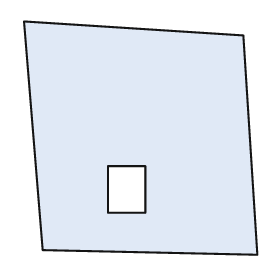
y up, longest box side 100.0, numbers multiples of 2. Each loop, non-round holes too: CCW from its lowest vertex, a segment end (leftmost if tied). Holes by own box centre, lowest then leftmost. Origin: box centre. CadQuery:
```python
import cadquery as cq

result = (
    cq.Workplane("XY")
    .moveTo(50.0, -50.0)
    .lineTo(44.0, 44.0)
    .lineTo(-50.0, 50.0)
    .lineTo(-42.0, -48.0)
    .close()
    .moveTo(-14.0, -32.0)
    .lineTo(2.0, -32.0)
    .lineTo(2.0, -12.0)
    .lineTo(-14.0, -12.0)
    .close()
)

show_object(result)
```